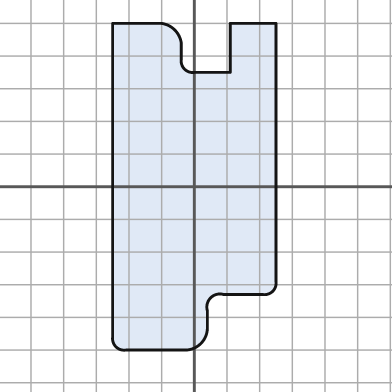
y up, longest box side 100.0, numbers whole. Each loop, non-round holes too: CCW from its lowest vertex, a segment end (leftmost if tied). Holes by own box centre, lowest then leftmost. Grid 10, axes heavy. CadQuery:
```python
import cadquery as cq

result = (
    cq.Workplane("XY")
    .moveTo(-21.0, -50.0)
    .lineTo(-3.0, -50.0)
    .threePointArc((2.0, -48.0), (4.0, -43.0))
    .lineTo(4.0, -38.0)
    .threePointArc((5.0, -34.0), (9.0, -33.0))
    .lineTo(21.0, -33.0)
    .threePointArc((24.0, -32.0), (25.0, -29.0))
    .lineTo(25.0, 50.0)
    .lineTo(11.0, 50.0)
    .lineTo(11.0, 35.0)
    .lineTo(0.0, 35.0)
    .threePointArc((-3.0, 36.0), (-4.0, 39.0))
    .lineTo(-4.0, 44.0)
    .threePointArc((-6.0, 48.0), (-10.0, 50.0))
    .lineTo(-25.0, 50.0)
    .lineTo(-25.0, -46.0)
    .threePointArc((-24.0, -49.0), (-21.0, -50.0))
    .close()
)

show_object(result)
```